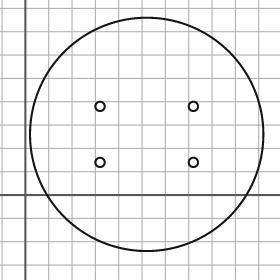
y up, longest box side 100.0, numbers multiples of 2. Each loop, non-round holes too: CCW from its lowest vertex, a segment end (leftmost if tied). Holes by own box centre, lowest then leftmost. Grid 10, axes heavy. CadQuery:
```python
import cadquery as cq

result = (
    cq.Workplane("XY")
    .moveTo(52.0, 26.0)
    .circle(50.0)
    .moveTo(32.0, 14.0)
    .circle(2.0)
    .moveTo(72.0, 14.0)
    .circle(2.0)
    .moveTo(32.0, 38.0)
    .circle(2.0)
    .moveTo(72.0, 38.0)
    .circle(2.0)
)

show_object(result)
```